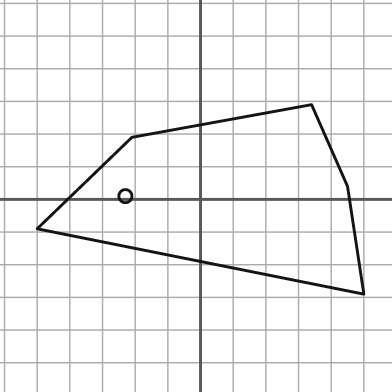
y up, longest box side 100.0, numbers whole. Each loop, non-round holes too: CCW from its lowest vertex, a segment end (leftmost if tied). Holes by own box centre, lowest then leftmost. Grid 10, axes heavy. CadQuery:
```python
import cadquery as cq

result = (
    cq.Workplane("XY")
    .moveTo(50.0, -29.0)
    .lineTo(45.0, 4.0)
    .lineTo(34.0, 29.0)
    .lineTo(-21.0, 19.0)
    .lineTo(-50.0, -9.0)
    .close()
    .moveTo(-23.0, 1.0)
    .circle(2.0)
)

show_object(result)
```